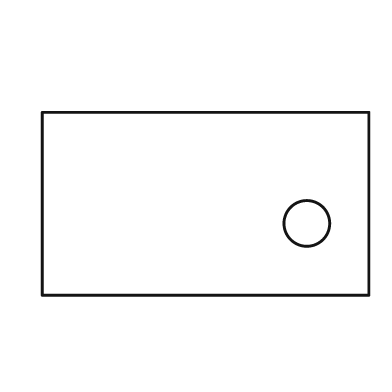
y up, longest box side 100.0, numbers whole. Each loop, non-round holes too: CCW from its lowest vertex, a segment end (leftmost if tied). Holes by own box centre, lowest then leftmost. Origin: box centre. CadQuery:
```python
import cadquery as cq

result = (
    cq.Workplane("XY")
    .moveTo(-50.0, -28.0)
    .lineTo(50.0, -28.0)
    .lineTo(50.0, 28.0)
    .lineTo(-50.0, 28.0)
    .close()
    .moveTo(31.0, -6.0)
    .circle(7.0)
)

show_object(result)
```